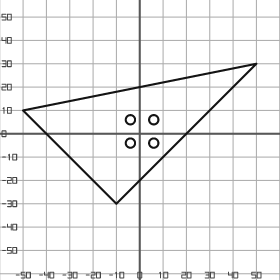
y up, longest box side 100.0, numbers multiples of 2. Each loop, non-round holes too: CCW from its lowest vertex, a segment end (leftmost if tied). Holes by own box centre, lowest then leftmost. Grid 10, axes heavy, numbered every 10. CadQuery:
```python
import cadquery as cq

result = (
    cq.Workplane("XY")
    .moveTo(-10.0, -30.0)
    .lineTo(50.0, 30.0)
    .lineTo(-50.0, 10.0)
    .close()
    .moveTo(-4.0, -4.0)
    .circle(2.0)
    .moveTo(6.0, -4.0)
    .circle(2.0)
    .moveTo(-4.0, 6.0)
    .circle(2.0)
    .moveTo(6.0, 6.0)
    .circle(2.0)
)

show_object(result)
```